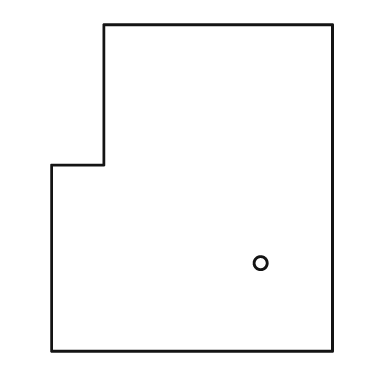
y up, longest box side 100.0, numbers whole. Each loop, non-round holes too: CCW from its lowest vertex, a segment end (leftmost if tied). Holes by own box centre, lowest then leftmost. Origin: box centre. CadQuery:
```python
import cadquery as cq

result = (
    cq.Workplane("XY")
    .moveTo(-43.0, -50.0)
    .lineTo(43.0, -50.0)
    .lineTo(43.0, 50.0)
    .lineTo(-27.0, 50.0)
    .lineTo(-27.0, 7.0)
    .lineTo(-43.0, 7.0)
    .close()
    .moveTo(21.0, -23.0)
    .circle(2.0)
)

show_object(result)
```